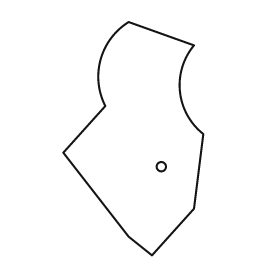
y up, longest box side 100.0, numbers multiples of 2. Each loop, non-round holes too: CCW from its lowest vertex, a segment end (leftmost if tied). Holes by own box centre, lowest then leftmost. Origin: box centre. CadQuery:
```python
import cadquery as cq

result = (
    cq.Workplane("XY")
    .moveTo(8.0, -50.0)
    .lineTo(26.0, -30.0)
    .lineTo(30.0, 2.0)
    .threePointArc((20.0, 20.0), (26.0, 40.0))
    .lineTo(-2.0, 50.0)
    .threePointArc((-14.0, 34.0), (-12.0, 14.0))
    .lineTo(-30.0, -6.0)
    .lineTo(-2.0, -42.0)
    .close()
    .moveTo(12.0, -12.0)
    .circle(2.0)
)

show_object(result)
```